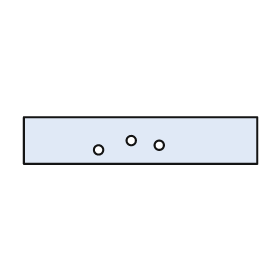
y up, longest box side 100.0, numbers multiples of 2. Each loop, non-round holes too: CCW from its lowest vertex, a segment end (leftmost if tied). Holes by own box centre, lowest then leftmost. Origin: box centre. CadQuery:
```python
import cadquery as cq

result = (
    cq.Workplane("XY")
    .moveTo(-50.0, -10.0)
    .lineTo(50.0, -10.0)
    .lineTo(50.0, 10.0)
    .lineTo(-50.0, 10.0)
    .close()
    .moveTo(-18.0, -4.0)
    .circle(2.0)
    .moveTo(8.0, -2.0)
    .circle(2.0)
    .moveTo(-4.0, 0.0)
    .circle(2.0)
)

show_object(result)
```